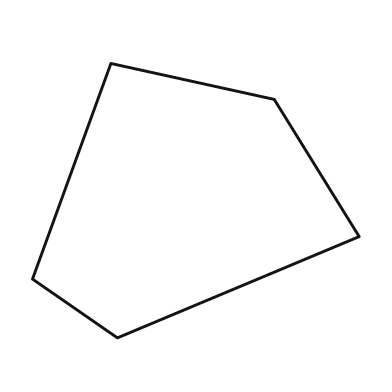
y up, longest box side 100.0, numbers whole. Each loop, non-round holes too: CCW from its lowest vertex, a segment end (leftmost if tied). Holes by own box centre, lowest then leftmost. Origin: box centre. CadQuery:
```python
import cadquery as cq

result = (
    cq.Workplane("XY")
    .moveTo(-24.0, -42.0)
    .lineTo(50.0, -11.0)
    .lineTo(24.0, 31.0)
    .lineTo(-26.0, 42.0)
    .lineTo(-50.0, -24.0)
    .close()
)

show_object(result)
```